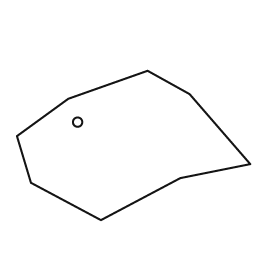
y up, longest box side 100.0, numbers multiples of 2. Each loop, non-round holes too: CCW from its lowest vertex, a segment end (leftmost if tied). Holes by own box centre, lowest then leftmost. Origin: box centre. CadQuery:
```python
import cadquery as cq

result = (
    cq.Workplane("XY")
    .moveTo(-14.0, -32.0)
    .lineTo(20.0, -14.0)
    .lineTo(50.0, -8.0)
    .lineTo(24.0, 22.0)
    .lineTo(6.0, 32.0)
    .lineTo(-28.0, 20.0)
    .lineTo(-50.0, 4.0)
    .lineTo(-44.0, -16.0)
    .close()
    .moveTo(-24.0, 10.0)
    .circle(2.0)
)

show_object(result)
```